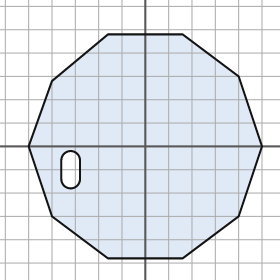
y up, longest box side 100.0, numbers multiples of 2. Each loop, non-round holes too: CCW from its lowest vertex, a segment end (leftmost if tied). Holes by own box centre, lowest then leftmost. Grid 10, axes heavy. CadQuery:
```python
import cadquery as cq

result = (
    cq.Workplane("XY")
    .moveTo(-16.0, -48.0)
    .lineTo(16.0, -48.0)
    .lineTo(40.0, -30.0)
    .lineTo(50.0, 0.0)
    .lineTo(40.0, 30.0)
    .lineTo(16.0, 48.0)
    .lineTo(-16.0, 48.0)
    .lineTo(-40.0, 28.0)
    .lineTo(-50.0, 0.0)
    .lineTo(-40.0, -30.0)
    .close()
    .moveTo(-36.0, -14.0)
    .threePointArc((-32.0, -18.0), (-28.0, -14.0))
    .lineTo(-28.0, -6.0)
    .threePointArc((-32.0, -2.0), (-36.0, -6.0))
    .close()
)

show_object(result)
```